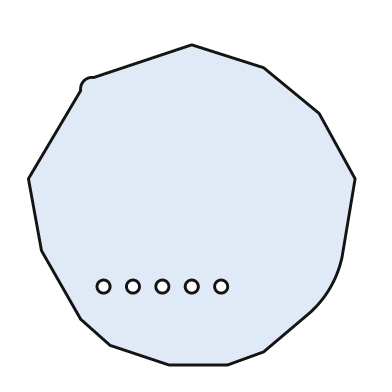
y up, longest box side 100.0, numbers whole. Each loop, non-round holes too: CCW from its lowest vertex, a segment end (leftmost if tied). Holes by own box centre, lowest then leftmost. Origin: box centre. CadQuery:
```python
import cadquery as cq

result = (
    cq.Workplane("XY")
    .moveTo(-7.0, -49.0)
    .lineTo(11.0, -49.0)
    .lineTo(22.0, -45.0)
    .lineTo(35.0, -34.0)
    .threePointArc((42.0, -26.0), (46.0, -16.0))
    .lineTo(50.0, 8.0)
    .lineTo(39.0, 28.0)
    .lineTo(22.0, 42.0)
    .lineTo(0.0, 49.0)
    .lineTo(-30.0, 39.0)
    .threePointArc((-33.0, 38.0), (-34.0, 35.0))
    .lineTo(-50.0, 8.0)
    .lineTo(-46.0, -14.0)
    .lineTo(-34.0, -35.0)
    .lineTo(-25.0, -43.0)
    .close()
    .moveTo(-27.0, -25.0)
    .circle(2.0)
    .moveTo(-18.0, -25.0)
    .circle(2.0)
    .moveTo(-9.0, -25.0)
    .circle(2.0)
    .moveTo(0.0, -25.0)
    .circle(2.0)
    .moveTo(9.0, -25.0)
    .circle(2.0)
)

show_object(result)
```